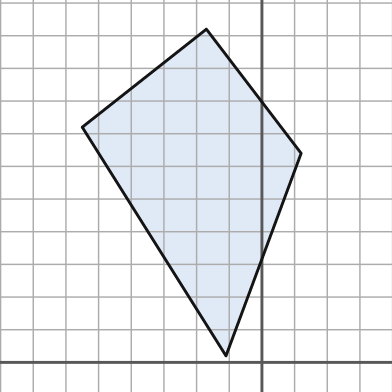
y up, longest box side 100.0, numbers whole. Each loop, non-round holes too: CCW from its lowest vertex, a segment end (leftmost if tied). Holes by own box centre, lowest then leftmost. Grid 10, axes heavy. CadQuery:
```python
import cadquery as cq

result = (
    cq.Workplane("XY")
    .moveTo(-11.0, 2.0)
    .lineTo(12.0, 64.0)
    .lineTo(-17.0, 102.0)
    .lineTo(-55.0, 72.0)
    .close()
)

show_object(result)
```